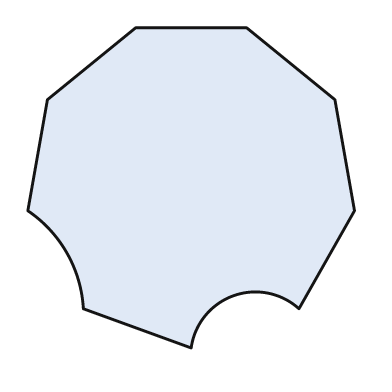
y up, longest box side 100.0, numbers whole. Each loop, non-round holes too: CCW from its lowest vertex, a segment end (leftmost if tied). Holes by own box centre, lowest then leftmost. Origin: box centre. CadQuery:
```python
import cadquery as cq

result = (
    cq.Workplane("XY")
    .moveTo(0.0, -49.0)
    .threePointArc((13.0, -33.0), (33.0, -37.0))
    .lineTo(50.0, -7.0)
    .lineTo(44.0, 27.0)
    .lineTo(17.0, 49.0)
    .lineTo(-17.0, 49.0)
    .lineTo(-44.0, 27.0)
    .lineTo(-50.0, -7.0)
    .threePointArc((-38.0, -20.0), (-33.0, -37.0))
    .close()
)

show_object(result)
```